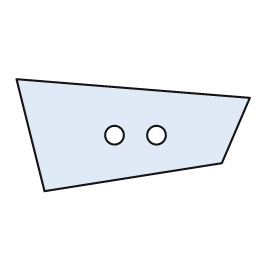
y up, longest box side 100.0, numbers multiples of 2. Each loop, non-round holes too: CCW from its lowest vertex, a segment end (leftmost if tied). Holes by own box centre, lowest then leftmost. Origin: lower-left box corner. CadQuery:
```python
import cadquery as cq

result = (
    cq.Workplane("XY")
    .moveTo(12.0, 0.0)
    .lineTo(88.0, 12.0)
    .lineTo(100.0, 40.0)
    .lineTo(0.0, 48.0)
    .close()
    .moveTo(42.0, 24.0)
    .circle(4.0)
    .moveTo(60.0, 24.0)
    .circle(4.0)
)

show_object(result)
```